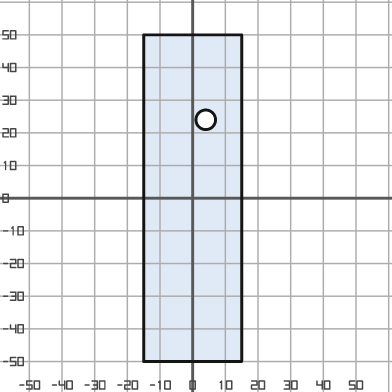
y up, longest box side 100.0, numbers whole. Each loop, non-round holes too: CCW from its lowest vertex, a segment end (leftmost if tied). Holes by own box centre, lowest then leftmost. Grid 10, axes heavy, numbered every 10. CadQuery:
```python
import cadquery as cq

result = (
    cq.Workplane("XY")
    .moveTo(-15.0, -50.0)
    .lineTo(15.0, -50.0)
    .lineTo(15.0, 50.0)
    .lineTo(-15.0, 50.0)
    .close()
    .moveTo(4.0, 24.0)
    .circle(3.0)
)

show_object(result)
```